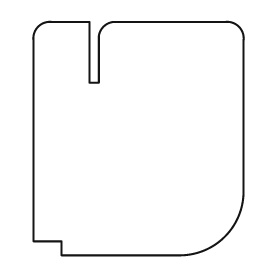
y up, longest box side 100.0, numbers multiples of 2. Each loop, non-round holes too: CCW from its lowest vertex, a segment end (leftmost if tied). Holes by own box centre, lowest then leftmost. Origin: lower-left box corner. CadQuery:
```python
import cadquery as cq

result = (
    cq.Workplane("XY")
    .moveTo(12.0, 0.0)
    .lineTo(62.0, 0.0)
    .threePointArc((82.0, 8.0), (90.0, 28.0))
    .lineTo(90.0, 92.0)
    .threePointArc((88.0, 98.0), (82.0, 100.0))
    .lineTo(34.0, 100.0)
    .threePointArc((30.0, 98.0), (28.0, 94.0))
    .lineTo(28.0, 74.0)
    .lineTo(24.0, 74.0)
    .lineTo(24.0, 100.0)
    .lineTo(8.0, 100.0)
    .threePointArc((2.0, 98.0), (0.0, 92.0))
    .lineTo(0.0, 6.0)
    .lineTo(12.0, 6.0)
    .close()
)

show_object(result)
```